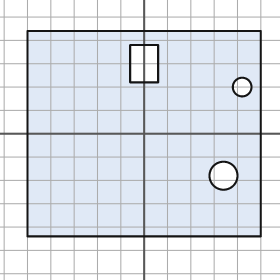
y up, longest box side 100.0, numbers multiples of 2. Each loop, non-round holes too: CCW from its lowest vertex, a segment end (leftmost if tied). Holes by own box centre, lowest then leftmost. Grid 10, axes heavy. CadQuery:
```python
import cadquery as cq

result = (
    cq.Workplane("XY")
    .moveTo(-50.0, -44.0)
    .lineTo(50.0, -44.0)
    .lineTo(50.0, 44.0)
    .lineTo(-50.0, 44.0)
    .close()
    .moveTo(34.0, -18.0)
    .circle(6.0)
    .moveTo(42.0, 20.0)
    .circle(4.0)
    .moveTo(-6.0, 22.0)
    .lineTo(6.0, 22.0)
    .lineTo(6.0, 38.0)
    .lineTo(-6.0, 38.0)
    .close()
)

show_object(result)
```